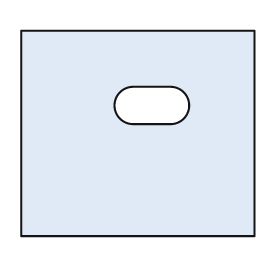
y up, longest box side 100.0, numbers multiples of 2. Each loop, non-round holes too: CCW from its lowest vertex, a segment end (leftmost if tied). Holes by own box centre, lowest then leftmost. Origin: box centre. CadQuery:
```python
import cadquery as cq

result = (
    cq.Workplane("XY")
    .moveTo(-50.0, -44.0)
    .lineTo(50.0, -44.0)
    .lineTo(50.0, 44.0)
    .lineTo(-50.0, 44.0)
    .close()
    .moveTo(-2.0, 4.0)
    .lineTo(14.0, 4.0)
    .threePointArc((22.0, 12.0), (14.0, 20.0))
    .lineTo(-2.0, 20.0)
    .threePointArc((-10.0, 12.0), (-2.0, 4.0))
    .close()
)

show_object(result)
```